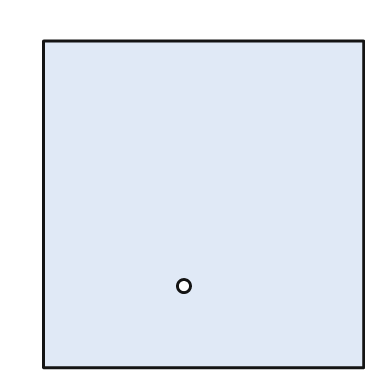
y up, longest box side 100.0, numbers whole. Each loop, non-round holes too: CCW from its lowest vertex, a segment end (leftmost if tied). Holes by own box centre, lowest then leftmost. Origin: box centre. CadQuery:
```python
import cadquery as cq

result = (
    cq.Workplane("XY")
    .moveTo(-49.0, -50.0)
    .lineTo(49.0, -50.0)
    .lineTo(49.0, 50.0)
    .lineTo(-49.0, 50.0)
    .close()
    .moveTo(-6.0, -25.0)
    .circle(2.0)
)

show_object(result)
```